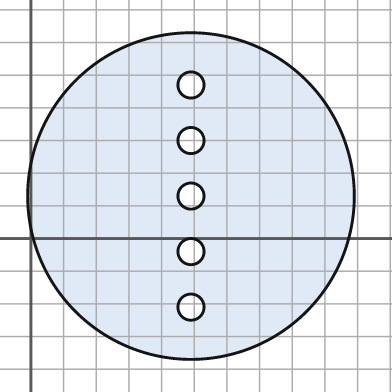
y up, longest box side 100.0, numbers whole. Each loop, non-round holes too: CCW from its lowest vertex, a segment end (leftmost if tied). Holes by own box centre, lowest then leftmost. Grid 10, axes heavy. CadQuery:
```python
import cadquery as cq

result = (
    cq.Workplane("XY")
    .moveTo(49.0, 13.0)
    .circle(50.0)
    .moveTo(49.0, -21.0)
    .circle(4.0)
    .moveTo(49.0, -4.0)
    .circle(4.0)
    .moveTo(49.0, 13.0)
    .circle(4.0)
    .moveTo(49.0, 30.0)
    .circle(4.0)
    .moveTo(49.0, 47.0)
    .circle(4.0)
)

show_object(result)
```